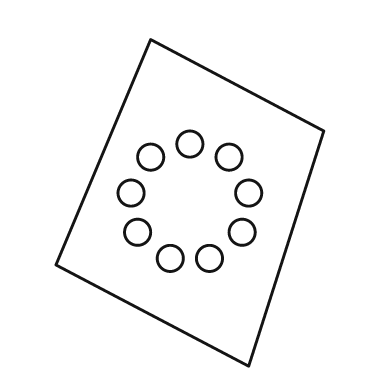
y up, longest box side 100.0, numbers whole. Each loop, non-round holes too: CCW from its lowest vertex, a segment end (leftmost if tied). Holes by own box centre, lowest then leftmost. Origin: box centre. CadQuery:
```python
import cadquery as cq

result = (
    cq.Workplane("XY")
    .moveTo(18.0, -50.0)
    .lineTo(41.0, 22.0)
    .lineTo(-12.0, 50.0)
    .lineTo(-41.0, -19.0)
    .close()
    .moveTo(-6.0, -17.0)
    .circle(4.0)
    .moveTo(6.0, -17.0)
    .circle(4.0)
    .moveTo(-16.0, -9.0)
    .circle(4.0)
    .moveTo(16.0, -9.0)
    .circle(4.0)
    .moveTo(-18.0, 3.0)
    .circle(4.0)
    .moveTo(18.0, 3.0)
    .circle(4.0)
    .moveTo(-12.0, 14.0)
    .circle(4.0)
    .moveTo(12.0, 14.0)
    .circle(4.0)
    .moveTo(0.0, 18.0)
    .circle(4.0)
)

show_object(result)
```